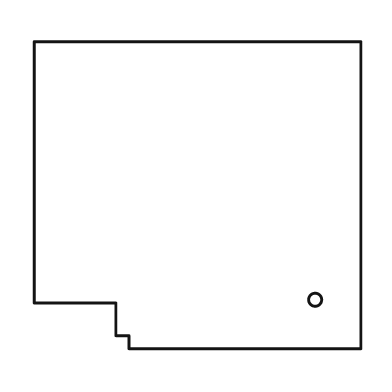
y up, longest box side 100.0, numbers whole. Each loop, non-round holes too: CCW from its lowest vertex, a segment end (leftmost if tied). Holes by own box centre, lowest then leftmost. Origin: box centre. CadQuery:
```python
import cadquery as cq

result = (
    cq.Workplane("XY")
    .moveTo(-21.0, -47.0)
    .lineTo(50.0, -47.0)
    .lineTo(50.0, 47.0)
    .lineTo(-50.0, 47.0)
    .lineTo(-50.0, -33.0)
    .lineTo(-25.0, -33.0)
    .lineTo(-25.0, -43.0)
    .lineTo(-21.0, -43.0)
    .close()
    .moveTo(36.0, -32.0)
    .circle(2.0)
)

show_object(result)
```